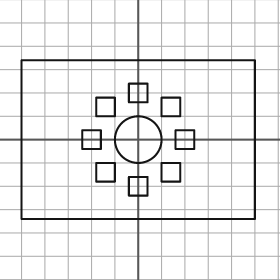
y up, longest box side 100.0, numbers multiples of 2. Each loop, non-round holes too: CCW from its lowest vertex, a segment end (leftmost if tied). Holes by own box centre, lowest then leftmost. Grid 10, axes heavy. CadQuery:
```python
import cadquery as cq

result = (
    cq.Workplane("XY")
    .moveTo(-50.0, -34.0)
    .lineTo(50.0, -34.0)
    .lineTo(50.0, 34.0)
    .lineTo(-50.0, 34.0)
    .close()
    .moveTo(-4.0, -24.0)
    .lineTo(4.0, -24.0)
    .lineTo(4.0, -16.0)
    .lineTo(-4.0, -16.0)
    .close()
    .moveTo(-18.0, -18.0)
    .lineTo(-10.0, -18.0)
    .lineTo(-10.0, -10.0)
    .lineTo(-18.0, -10.0)
    .close()
    .moveTo(10.0, -18.0)
    .lineTo(18.0, -18.0)
    .lineTo(18.0, -10.0)
    .lineTo(10.0, -10.0)
    .close()
    .moveTo(-24.0, -4.0)
    .lineTo(-16.0, -4.0)
    .lineTo(-16.0, 4.0)
    .lineTo(-24.0, 4.0)
    .close()
    .moveTo(0.0, 0.0)
    .circle(10.0)
    .moveTo(16.0, -4.0)
    .lineTo(24.0, -4.0)
    .lineTo(24.0, 4.0)
    .lineTo(16.0, 4.0)
    .close()
    .moveTo(-18.0, 10.0)
    .lineTo(-10.0, 10.0)
    .lineTo(-10.0, 18.0)
    .lineTo(-18.0, 18.0)
    .close()
    .moveTo(10.0, 10.0)
    .lineTo(18.0, 10.0)
    .lineTo(18.0, 18.0)
    .lineTo(10.0, 18.0)
    .close()
    .moveTo(-4.0, 16.0)
    .lineTo(4.0, 16.0)
    .lineTo(4.0, 24.0)
    .lineTo(-4.0, 24.0)
    .close()
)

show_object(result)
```